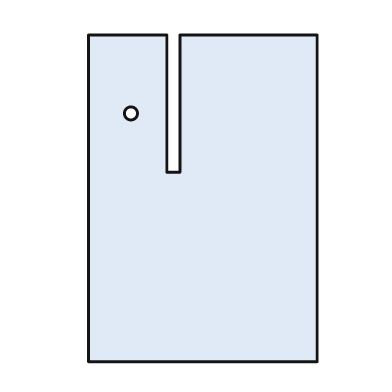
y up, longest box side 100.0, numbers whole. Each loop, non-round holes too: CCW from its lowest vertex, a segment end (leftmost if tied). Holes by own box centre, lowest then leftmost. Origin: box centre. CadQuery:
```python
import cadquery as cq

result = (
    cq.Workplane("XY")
    .moveTo(-35.0, -50.0)
    .lineTo(35.0, -50.0)
    .lineTo(35.0, 50.0)
    .lineTo(-7.0, 50.0)
    .lineTo(-7.0, 8.0)
    .lineTo(-11.0, 8.0)
    .lineTo(-11.0, 50.0)
    .lineTo(-35.0, 50.0)
    .close()
    .moveTo(-22.0, 26.0)
    .circle(2.0)
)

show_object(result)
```